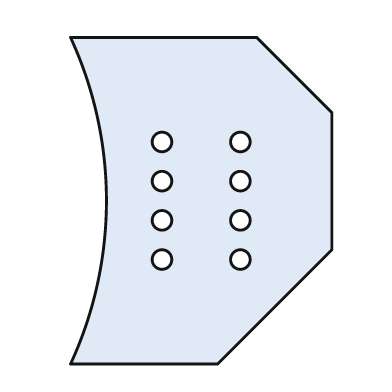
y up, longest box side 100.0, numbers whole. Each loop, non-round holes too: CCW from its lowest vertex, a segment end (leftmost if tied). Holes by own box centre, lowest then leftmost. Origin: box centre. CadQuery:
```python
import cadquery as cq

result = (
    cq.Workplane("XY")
    .moveTo(-40.0, -50.0)
    .lineTo(5.0, -50.0)
    .lineTo(40.0, -15.0)
    .lineTo(40.0, 27.0)
    .lineTo(17.0, 50.0)
    .lineTo(-40.0, 50.0)
    .threePointArc((-29.0, 0.0), (-40.0, -50.0))
    .close()
    .moveTo(-12.0, -18.0)
    .circle(3.0)
    .moveTo(12.0, -18.0)
    .circle(3.0)
    .moveTo(-12.0, -6.0)
    .circle(3.0)
    .moveTo(12.0, -6.0)
    .circle(3.0)
    .moveTo(-12.0, 6.0)
    .circle(3.0)
    .moveTo(12.0, 6.0)
    .circle(3.0)
    .moveTo(-12.0, 18.0)
    .circle(3.0)
    .moveTo(12.0, 18.0)
    .circle(3.0)
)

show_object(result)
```